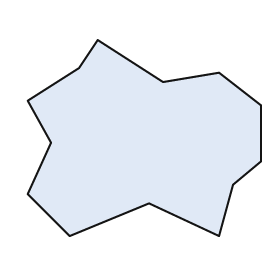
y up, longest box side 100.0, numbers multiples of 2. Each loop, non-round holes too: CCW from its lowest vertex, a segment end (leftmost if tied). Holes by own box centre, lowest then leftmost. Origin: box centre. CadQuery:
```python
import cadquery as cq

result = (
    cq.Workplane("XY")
    .moveTo(-32.0, -42.0)
    .lineTo(2.0, -28.0)
    .lineTo(32.0, -42.0)
    .lineTo(38.0, -20.0)
    .lineTo(50.0, -10.0)
    .lineTo(50.0, 14.0)
    .lineTo(32.0, 28.0)
    .lineTo(8.0, 24.0)
    .lineTo(-20.0, 42.0)
    .lineTo(-28.0, 30.0)
    .lineTo(-50.0, 16.0)
    .lineTo(-40.0, -2.0)
    .lineTo(-50.0, -24.0)
    .close()
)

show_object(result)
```